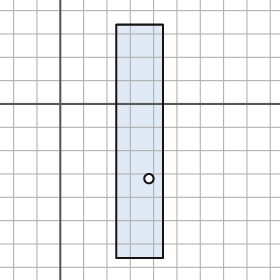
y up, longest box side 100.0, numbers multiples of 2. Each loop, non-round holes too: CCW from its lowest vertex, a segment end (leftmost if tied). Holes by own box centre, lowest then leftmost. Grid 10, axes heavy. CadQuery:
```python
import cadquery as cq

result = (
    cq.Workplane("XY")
    .moveTo(24.0, -66.0)
    .lineTo(44.0, -66.0)
    .lineTo(44.0, 34.0)
    .lineTo(24.0, 34.0)
    .close()
    .moveTo(38.0, -32.0)
    .circle(2.0)
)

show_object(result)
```